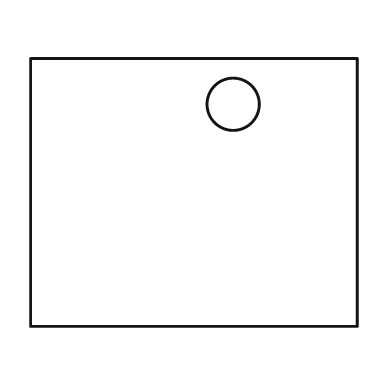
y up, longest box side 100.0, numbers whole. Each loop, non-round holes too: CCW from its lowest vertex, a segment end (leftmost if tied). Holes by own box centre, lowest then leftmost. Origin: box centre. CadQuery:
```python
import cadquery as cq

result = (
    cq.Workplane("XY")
    .moveTo(-50.0, -41.0)
    .lineTo(50.0, -41.0)
    .lineTo(50.0, 41.0)
    .lineTo(-50.0, 41.0)
    .close()
    .moveTo(12.0, 27.0)
    .circle(8.0)
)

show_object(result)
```